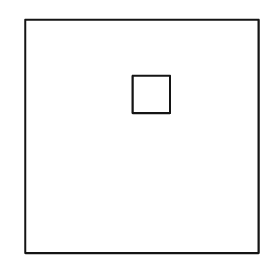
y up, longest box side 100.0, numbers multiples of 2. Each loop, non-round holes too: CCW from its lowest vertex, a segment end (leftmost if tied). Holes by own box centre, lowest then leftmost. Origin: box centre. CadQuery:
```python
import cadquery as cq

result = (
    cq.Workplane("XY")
    .moveTo(-50.0, -50.0)
    .lineTo(50.0, -50.0)
    .lineTo(50.0, 50.0)
    .lineTo(-50.0, 50.0)
    .close()
    .moveTo(-4.0, 10.0)
    .lineTo(12.0, 10.0)
    .lineTo(12.0, 26.0)
    .lineTo(-4.0, 26.0)
    .close()
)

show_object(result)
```